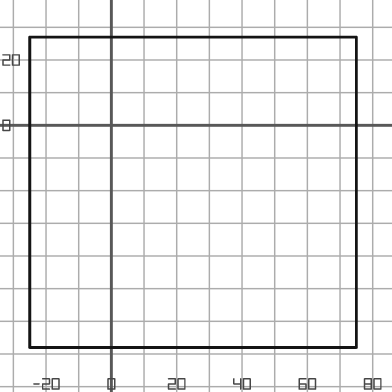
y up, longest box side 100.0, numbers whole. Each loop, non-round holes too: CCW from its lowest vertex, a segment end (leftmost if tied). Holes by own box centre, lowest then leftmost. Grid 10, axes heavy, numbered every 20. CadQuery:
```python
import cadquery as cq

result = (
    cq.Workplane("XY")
    .moveTo(-25.0, -68.0)
    .lineTo(75.0, -68.0)
    .lineTo(75.0, 27.0)
    .lineTo(-25.0, 27.0)
    .close()
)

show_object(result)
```